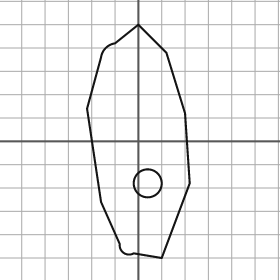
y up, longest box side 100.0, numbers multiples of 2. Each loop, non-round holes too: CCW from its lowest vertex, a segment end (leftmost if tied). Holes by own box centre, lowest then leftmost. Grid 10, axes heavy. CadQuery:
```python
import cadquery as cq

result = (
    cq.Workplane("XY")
    .moveTo(10.0, -50.0)
    .lineTo(22.0, -18.0)
    .lineTo(20.0, 12.0)
    .lineTo(12.0, 38.0)
    .lineTo(0.0, 50.0)
    .lineTo(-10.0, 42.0)
    .threePointArc((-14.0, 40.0), (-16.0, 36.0))
    .lineTo(-22.0, 14.0)
    .lineTo(-16.0, -26.0)
    .lineTo(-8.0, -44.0)
    .threePointArc((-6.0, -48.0), (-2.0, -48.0))
    .close()
    .moveTo(4.0, -18.0)
    .circle(6.0)
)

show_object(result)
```